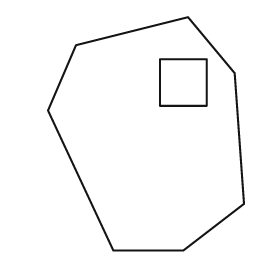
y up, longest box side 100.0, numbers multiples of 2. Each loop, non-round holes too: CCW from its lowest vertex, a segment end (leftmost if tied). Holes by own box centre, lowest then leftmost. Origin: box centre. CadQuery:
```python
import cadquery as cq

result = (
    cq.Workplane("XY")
    .moveTo(-14.0, -50.0)
    .lineTo(16.0, -50.0)
    .lineTo(42.0, -30.0)
    .lineTo(38.0, 26.0)
    .lineTo(18.0, 50.0)
    .lineTo(-30.0, 38.0)
    .lineTo(-42.0, 10.0)
    .close()
    .moveTo(6.0, 12.0)
    .lineTo(26.0, 12.0)
    .lineTo(26.0, 32.0)
    .lineTo(6.0, 32.0)
    .close()
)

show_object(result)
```